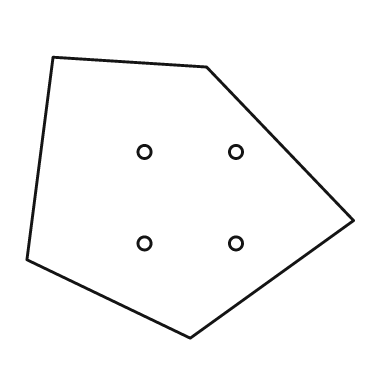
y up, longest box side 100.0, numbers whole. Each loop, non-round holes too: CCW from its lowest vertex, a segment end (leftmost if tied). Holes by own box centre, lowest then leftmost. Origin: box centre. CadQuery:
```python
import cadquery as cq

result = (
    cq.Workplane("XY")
    .moveTo(0.0, -43.0)
    .lineTo(50.0, -7.0)
    .lineTo(5.0, 40.0)
    .lineTo(-42.0, 43.0)
    .lineTo(-50.0, -19.0)
    .close()
    .moveTo(-14.0, -14.0)
    .circle(2.0)
    .moveTo(14.0, -14.0)
    .circle(2.0)
    .moveTo(-14.0, 14.0)
    .circle(2.0)
    .moveTo(14.0, 14.0)
    .circle(2.0)
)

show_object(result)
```